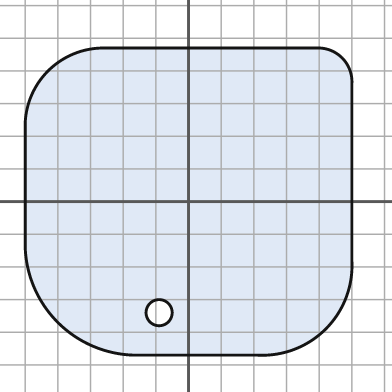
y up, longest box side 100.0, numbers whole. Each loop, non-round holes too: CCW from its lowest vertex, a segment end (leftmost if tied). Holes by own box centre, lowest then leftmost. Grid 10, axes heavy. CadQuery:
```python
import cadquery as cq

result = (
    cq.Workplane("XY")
    .moveTo(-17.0, -47.0)
    .lineTo(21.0, -47.0)
    .threePointArc((42.0, -39.0), (50.0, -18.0))
    .lineTo(50.0, 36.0)
    .threePointArc((47.0, 44.0), (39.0, 47.0))
    .lineTo(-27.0, 47.0)
    .threePointArc((-43.0, 40.0), (-50.0, 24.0))
    .lineTo(-50.0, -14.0)
    .threePointArc((-40.0, -37.0), (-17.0, -47.0))
    .close()
    .moveTo(-9.0, -34.0)
    .circle(4.0)
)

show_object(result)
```